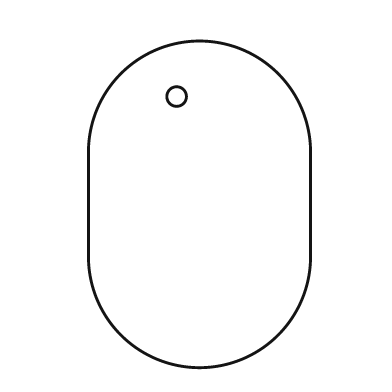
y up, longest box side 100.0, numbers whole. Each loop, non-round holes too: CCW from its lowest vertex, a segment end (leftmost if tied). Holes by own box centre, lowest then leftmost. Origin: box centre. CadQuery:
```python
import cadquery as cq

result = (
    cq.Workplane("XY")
    .moveTo(-34.0, -16.0)
    .threePointArc((0.0, -50.0), (34.0, -16.0))
    .lineTo(34.0, 16.0)
    .threePointArc((0.0, 50.0), (-34.0, 16.0))
    .close()
    .moveTo(-7.0, 33.0)
    .circle(3.0)
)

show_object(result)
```